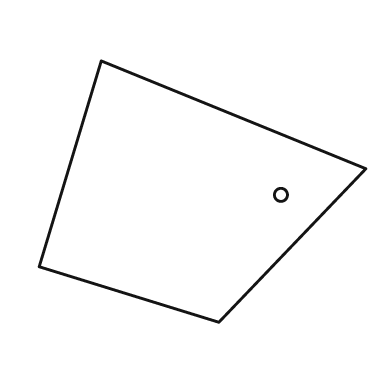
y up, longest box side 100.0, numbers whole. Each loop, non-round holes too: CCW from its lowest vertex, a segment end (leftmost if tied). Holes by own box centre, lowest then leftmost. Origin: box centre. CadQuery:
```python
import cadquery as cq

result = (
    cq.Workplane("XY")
    .moveTo(5.0, -40.0)
    .lineTo(50.0, 7.0)
    .lineTo(-31.0, 40.0)
    .lineTo(-50.0, -23.0)
    .close()
    .moveTo(24.0, -1.0)
    .circle(2.0)
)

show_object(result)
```